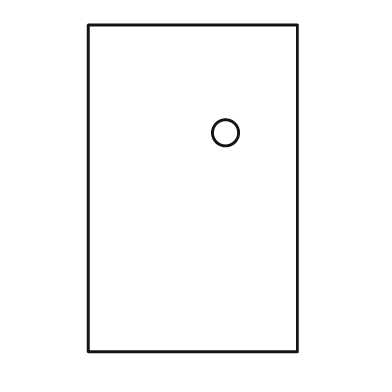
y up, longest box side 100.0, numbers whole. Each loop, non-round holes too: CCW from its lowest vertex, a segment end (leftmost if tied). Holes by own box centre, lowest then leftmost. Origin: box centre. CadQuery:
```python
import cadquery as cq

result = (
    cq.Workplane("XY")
    .moveTo(-32.0, -50.0)
    .lineTo(32.0, -50.0)
    .lineTo(32.0, 50.0)
    .lineTo(-32.0, 50.0)
    .close()
    .moveTo(10.0, 17.0)
    .circle(4.0)
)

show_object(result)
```